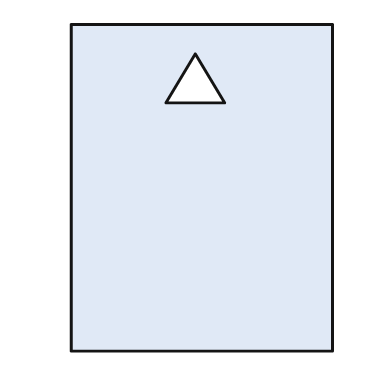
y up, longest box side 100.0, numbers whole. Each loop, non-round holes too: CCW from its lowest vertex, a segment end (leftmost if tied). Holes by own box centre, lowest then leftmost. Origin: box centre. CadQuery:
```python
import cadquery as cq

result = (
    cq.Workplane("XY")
    .moveTo(-40.0, -50.0)
    .lineTo(40.0, -50.0)
    .lineTo(40.0, 50.0)
    .lineTo(-40.0, 50.0)
    .close()
    .moveTo(-11.0, 26.0)
    .lineTo(7.0, 26.0)
    .lineTo(-2.0, 41.0)
    .close()
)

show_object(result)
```